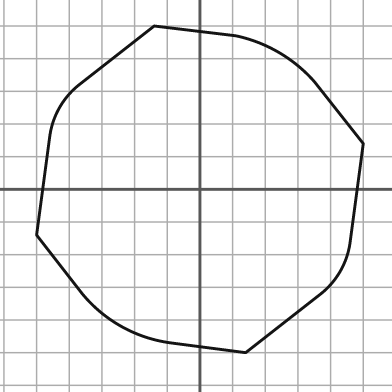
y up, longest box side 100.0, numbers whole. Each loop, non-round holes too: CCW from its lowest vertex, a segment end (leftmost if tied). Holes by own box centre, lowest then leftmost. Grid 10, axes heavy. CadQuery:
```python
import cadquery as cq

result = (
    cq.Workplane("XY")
    .moveTo(14.0, -50.0)
    .lineTo(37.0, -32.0)
    .threePointArc((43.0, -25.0), (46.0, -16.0))
    .lineTo(50.0, 14.0)
    .lineTo(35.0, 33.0)
    .threePointArc((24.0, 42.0), (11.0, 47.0))
    .lineTo(-14.0, 50.0)
    .lineTo(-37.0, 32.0)
    .threePointArc((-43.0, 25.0), (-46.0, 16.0))
    .lineTo(-50.0, -14.0)
    .lineTo(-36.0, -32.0)
    .threePointArc((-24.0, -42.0), (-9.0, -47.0))
    .close()
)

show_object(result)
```